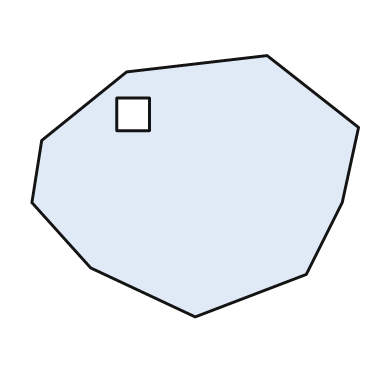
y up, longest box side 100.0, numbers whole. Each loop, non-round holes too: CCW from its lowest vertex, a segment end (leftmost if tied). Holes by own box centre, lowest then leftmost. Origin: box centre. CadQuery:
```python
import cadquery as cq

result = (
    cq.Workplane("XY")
    .moveTo(0.0, -40.0)
    .lineTo(34.0, -27.0)
    .lineTo(45.0, -5.0)
    .lineTo(50.0, 18.0)
    .lineTo(22.0, 40.0)
    .lineTo(-21.0, 35.0)
    .lineTo(-47.0, 14.0)
    .lineTo(-50.0, -5.0)
    .lineTo(-32.0, -25.0)
    .close()
    .moveTo(-24.0, 17.0)
    .lineTo(-14.0, 17.0)
    .lineTo(-14.0, 27.0)
    .lineTo(-24.0, 27.0)
    .close()
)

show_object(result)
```